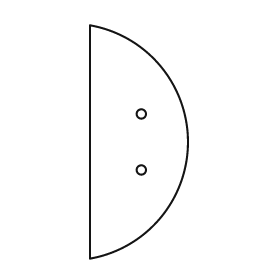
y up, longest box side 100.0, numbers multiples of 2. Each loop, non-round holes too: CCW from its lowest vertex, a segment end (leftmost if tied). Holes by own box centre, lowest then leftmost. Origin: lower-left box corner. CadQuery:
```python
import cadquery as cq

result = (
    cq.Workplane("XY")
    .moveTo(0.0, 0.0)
    .threePointArc((42.0, 50.0), (0.0, 100.0))
    .close()
    .moveTo(22.0, 38.0)
    .circle(2.0)
    .moveTo(22.0, 62.0)
    .circle(2.0)
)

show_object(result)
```